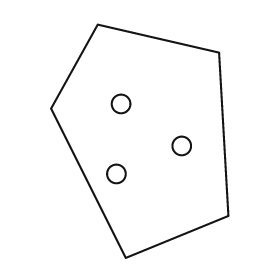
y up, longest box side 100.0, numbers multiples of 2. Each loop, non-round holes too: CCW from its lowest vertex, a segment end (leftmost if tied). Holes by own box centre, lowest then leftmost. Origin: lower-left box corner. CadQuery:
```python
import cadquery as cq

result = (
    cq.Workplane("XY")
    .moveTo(32.0, 0.0)
    .lineTo(76.0, 18.0)
    .lineTo(72.0, 88.0)
    .lineTo(20.0, 100.0)
    .lineTo(0.0, 64.0)
    .close()
    .moveTo(28.0, 36.0)
    .circle(4.0)
    .moveTo(56.0, 48.0)
    .circle(4.0)
    .moveTo(30.0, 66.0)
    .circle(4.0)
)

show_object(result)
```